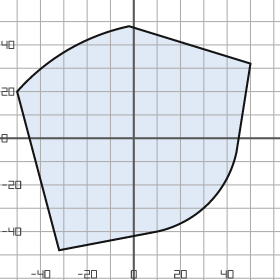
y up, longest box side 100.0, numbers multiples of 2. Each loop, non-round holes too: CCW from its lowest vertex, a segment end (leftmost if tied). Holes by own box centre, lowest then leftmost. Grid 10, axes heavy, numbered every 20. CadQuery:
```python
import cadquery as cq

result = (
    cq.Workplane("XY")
    .moveTo(-32.0, -48.0)
    .lineTo(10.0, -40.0)
    .threePointArc((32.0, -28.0), (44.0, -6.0))
    .lineTo(50.0, 32.0)
    .lineTo(-2.0, 48.0)
    .threePointArc((-28.0, 38.0), (-50.0, 20.0))
    .close()
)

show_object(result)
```